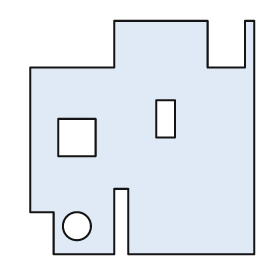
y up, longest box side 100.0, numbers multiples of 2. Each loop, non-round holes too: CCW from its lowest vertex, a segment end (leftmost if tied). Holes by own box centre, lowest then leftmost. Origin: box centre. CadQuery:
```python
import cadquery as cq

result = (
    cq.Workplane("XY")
    .moveTo(-38.0, -50.0)
    .lineTo(-12.0, -50.0)
    .lineTo(-12.0, -22.0)
    .lineTo(-6.0, -22.0)
    .lineTo(-6.0, -50.0)
    .lineTo(48.0, -50.0)
    .lineTo(48.0, 50.0)
    .lineTo(44.0, 50.0)
    .lineTo(44.0, 30.0)
    .lineTo(28.0, 30.0)
    .lineTo(28.0, 50.0)
    .lineTo(-12.0, 50.0)
    .lineTo(-12.0, 30.0)
    .lineTo(-48.0, 30.0)
    .lineTo(-48.0, -32.0)
    .lineTo(-38.0, -32.0)
    .close()
    .moveTo(-28.0, -38.0)
    .circle(6.0)
    .moveTo(-36.0, -8.0)
    .lineTo(-20.0, -8.0)
    .lineTo(-20.0, 8.0)
    .lineTo(-36.0, 8.0)
    .close()
    .moveTo(6.0, 0.0)
    .lineTo(14.0, 0.0)
    .lineTo(14.0, 16.0)
    .lineTo(6.0, 16.0)
    .close()
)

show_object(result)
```